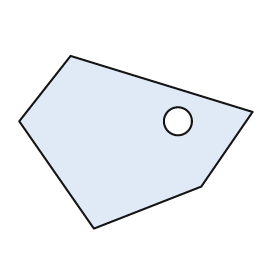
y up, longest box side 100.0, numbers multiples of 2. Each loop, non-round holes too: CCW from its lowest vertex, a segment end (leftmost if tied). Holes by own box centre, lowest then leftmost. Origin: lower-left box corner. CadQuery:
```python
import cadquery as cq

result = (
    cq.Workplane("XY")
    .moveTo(32.0, 0.0)
    .lineTo(78.0, 18.0)
    .lineTo(100.0, 50.0)
    .lineTo(22.0, 74.0)
    .lineTo(0.0, 46.0)
    .close()
    .moveTo(68.0, 46.0)
    .circle(6.0)
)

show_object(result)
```